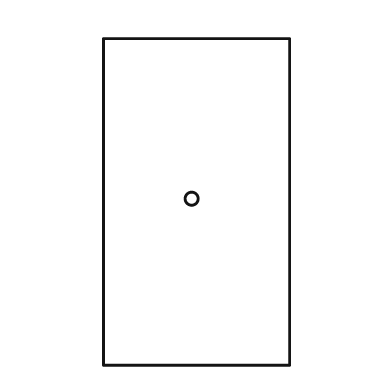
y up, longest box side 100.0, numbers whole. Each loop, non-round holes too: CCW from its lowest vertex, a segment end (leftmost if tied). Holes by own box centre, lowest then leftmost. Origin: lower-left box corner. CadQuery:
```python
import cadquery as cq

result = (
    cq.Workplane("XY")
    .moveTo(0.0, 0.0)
    .lineTo(57.0, 0.0)
    .lineTo(57.0, 100.0)
    .lineTo(0.0, 100.0)
    .close()
    .moveTo(27.0, 51.0)
    .circle(2.0)
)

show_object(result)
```